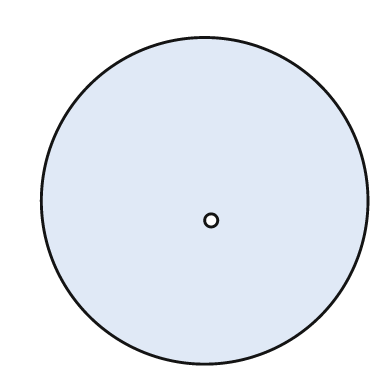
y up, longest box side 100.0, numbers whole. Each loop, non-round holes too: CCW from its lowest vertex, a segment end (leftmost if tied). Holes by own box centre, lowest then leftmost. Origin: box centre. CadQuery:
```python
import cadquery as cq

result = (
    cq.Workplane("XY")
    .moveTo(0.0, 0.0)
    .circle(50.0)
    .moveTo(2.0, -6.0)
    .circle(2.0)
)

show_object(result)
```